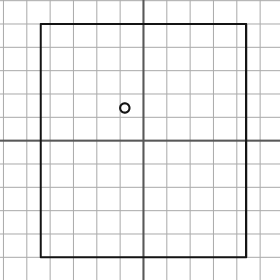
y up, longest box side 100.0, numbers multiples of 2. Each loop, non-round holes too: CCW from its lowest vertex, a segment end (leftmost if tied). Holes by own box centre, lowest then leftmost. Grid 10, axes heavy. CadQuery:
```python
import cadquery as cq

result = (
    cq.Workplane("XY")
    .moveTo(-44.0, -50.0)
    .lineTo(44.0, -50.0)
    .lineTo(44.0, 50.0)
    .lineTo(-44.0, 50.0)
    .close()
    .moveTo(-8.0, 14.0)
    .circle(2.0)
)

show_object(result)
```